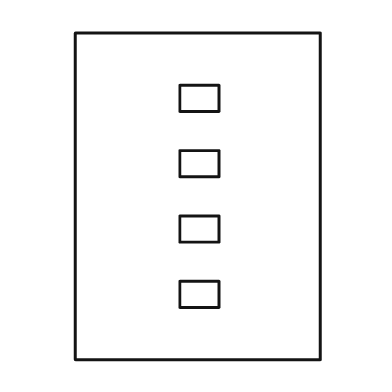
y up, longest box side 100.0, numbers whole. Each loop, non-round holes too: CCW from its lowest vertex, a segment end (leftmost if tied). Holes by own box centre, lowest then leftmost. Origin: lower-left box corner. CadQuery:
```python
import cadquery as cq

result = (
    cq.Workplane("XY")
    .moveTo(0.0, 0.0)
    .lineTo(75.0, 0.0)
    .lineTo(75.0, 100.0)
    .lineTo(0.0, 100.0)
    .close()
    .moveTo(32.0, 16.0)
    .lineTo(44.0, 16.0)
    .lineTo(44.0, 24.0)
    .lineTo(32.0, 24.0)
    .close()
    .moveTo(32.0, 36.0)
    .lineTo(44.0, 36.0)
    .lineTo(44.0, 44.0)
    .lineTo(32.0, 44.0)
    .close()
    .moveTo(32.0, 56.0)
    .lineTo(44.0, 56.0)
    .lineTo(44.0, 64.0)
    .lineTo(32.0, 64.0)
    .close()
    .moveTo(32.0, 76.0)
    .lineTo(44.0, 76.0)
    .lineTo(44.0, 84.0)
    .lineTo(32.0, 84.0)
    .close()
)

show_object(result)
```